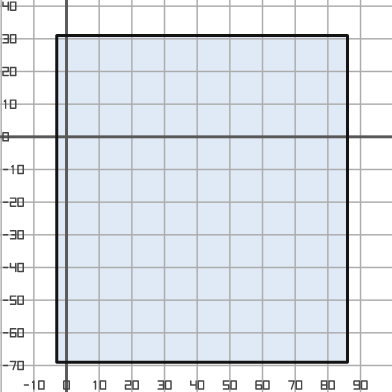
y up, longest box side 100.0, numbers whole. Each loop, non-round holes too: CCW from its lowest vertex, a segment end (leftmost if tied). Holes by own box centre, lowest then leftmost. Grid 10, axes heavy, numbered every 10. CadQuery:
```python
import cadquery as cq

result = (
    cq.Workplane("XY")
    .moveTo(-3.0, -69.0)
    .lineTo(86.0, -69.0)
    .lineTo(86.0, 31.0)
    .lineTo(-3.0, 31.0)
    .close()
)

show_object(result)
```